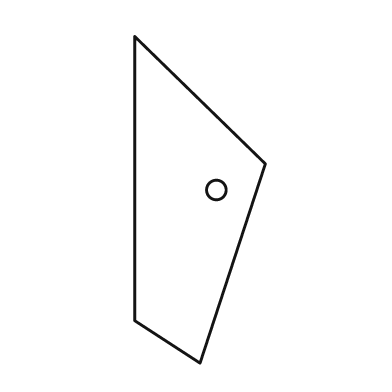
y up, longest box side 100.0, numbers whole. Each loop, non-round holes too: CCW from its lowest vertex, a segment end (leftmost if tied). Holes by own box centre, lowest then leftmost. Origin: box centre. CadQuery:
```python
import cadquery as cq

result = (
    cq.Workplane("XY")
    .moveTo(0.0, -50.0)
    .lineTo(20.0, 11.0)
    .lineTo(-20.0, 50.0)
    .lineTo(-20.0, -37.0)
    .close()
    .moveTo(5.0, 3.0)
    .circle(3.0)
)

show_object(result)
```